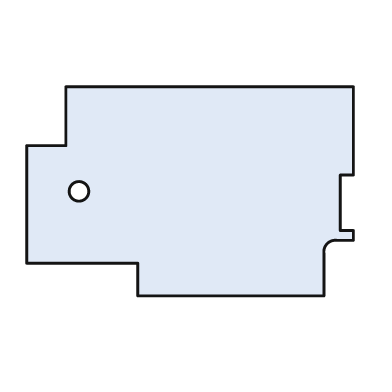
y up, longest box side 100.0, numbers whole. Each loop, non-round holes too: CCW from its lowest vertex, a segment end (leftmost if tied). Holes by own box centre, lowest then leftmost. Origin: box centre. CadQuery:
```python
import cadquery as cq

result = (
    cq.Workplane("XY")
    .moveTo(-16.0, -32.0)
    .lineTo(41.0, -32.0)
    .lineTo(41.0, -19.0)
    .threePointArc((42.0, -16.0), (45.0, -15.0))
    .lineTo(50.0, -15.0)
    .lineTo(50.0, -12.0)
    .lineTo(46.0, -12.0)
    .lineTo(46.0, 5.0)
    .lineTo(50.0, 5.0)
    .lineTo(50.0, 32.0)
    .lineTo(-38.0, 32.0)
    .lineTo(-38.0, 14.0)
    .lineTo(-50.0, 14.0)
    .lineTo(-50.0, -22.0)
    .lineTo(-16.0, -22.0)
    .close()
    .moveTo(-34.0, 0.0)
    .circle(3.0)
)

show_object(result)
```